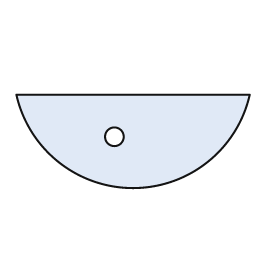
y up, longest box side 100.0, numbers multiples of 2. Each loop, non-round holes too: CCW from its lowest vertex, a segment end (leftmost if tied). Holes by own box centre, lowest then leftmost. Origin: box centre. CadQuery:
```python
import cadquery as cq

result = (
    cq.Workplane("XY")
    .moveTo(-50.0, 20.0)
    .threePointArc((0.0, -20.0), (50.0, 20.0))
    .close()
    .moveTo(-8.0, 2.0)
    .circle(4.0)
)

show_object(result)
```